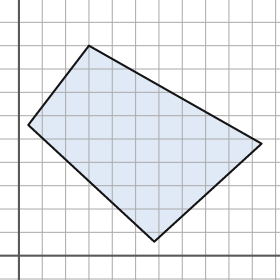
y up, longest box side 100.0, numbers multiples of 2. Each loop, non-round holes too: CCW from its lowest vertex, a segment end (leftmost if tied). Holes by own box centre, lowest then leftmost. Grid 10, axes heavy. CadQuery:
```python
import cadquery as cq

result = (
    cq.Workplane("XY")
    .moveTo(58.0, 6.0)
    .lineTo(104.0, 48.0)
    .lineTo(30.0, 90.0)
    .lineTo(4.0, 56.0)
    .close()
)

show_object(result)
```